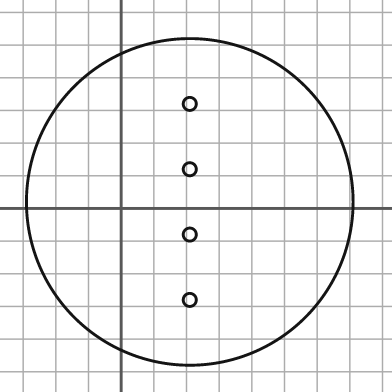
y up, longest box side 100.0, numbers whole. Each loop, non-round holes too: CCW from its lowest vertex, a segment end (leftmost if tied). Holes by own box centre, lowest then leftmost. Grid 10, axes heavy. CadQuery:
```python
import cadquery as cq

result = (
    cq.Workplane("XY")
    .moveTo(21.0, 2.0)
    .circle(50.0)
    .moveTo(21.0, -28.0)
    .circle(2.0)
    .moveTo(21.0, -8.0)
    .circle(2.0)
    .moveTo(21.0, 12.0)
    .circle(2.0)
    .moveTo(21.0, 32.0)
    .circle(2.0)
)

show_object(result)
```